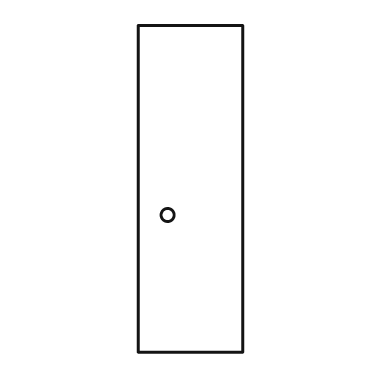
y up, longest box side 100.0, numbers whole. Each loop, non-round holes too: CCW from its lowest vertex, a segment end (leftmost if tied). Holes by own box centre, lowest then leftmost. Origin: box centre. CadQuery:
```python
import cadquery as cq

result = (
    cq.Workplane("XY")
    .moveTo(-16.0, -50.0)
    .lineTo(16.0, -50.0)
    .lineTo(16.0, 50.0)
    .lineTo(-16.0, 50.0)
    .close()
    .moveTo(-7.0, -8.0)
    .circle(2.0)
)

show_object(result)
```